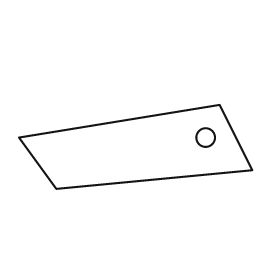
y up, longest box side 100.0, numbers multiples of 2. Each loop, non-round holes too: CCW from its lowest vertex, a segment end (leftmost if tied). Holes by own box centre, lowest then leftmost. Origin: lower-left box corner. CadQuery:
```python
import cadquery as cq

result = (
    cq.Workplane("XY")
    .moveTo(16.0, 0.0)
    .lineTo(100.0, 8.0)
    .lineTo(86.0, 36.0)
    .lineTo(0.0, 22.0)
    .close()
    .moveTo(80.0, 22.0)
    .circle(4.0)
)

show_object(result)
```